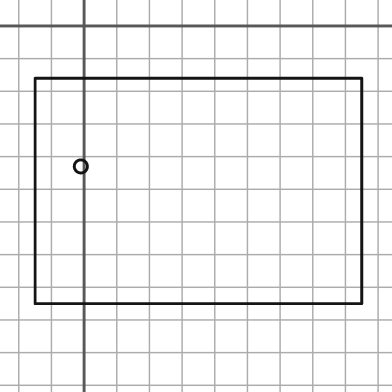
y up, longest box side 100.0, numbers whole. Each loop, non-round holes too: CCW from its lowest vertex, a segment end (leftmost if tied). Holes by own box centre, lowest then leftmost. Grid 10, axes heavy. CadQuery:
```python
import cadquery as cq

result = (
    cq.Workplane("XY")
    .moveTo(-15.0, -85.0)
    .lineTo(85.0, -85.0)
    .lineTo(85.0, -16.0)
    .lineTo(-15.0, -16.0)
    .close()
    .moveTo(-1.0, -43.0)
    .circle(2.0)
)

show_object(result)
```